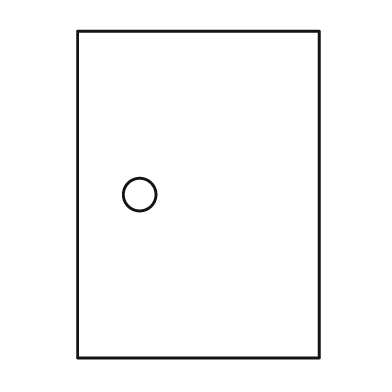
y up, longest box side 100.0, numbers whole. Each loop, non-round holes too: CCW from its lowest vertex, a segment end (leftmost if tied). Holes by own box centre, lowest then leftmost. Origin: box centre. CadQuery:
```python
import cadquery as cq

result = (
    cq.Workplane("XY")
    .moveTo(-37.0, -50.0)
    .lineTo(37.0, -50.0)
    .lineTo(37.0, 50.0)
    .lineTo(-37.0, 50.0)
    .close()
    .moveTo(-18.0, 0.0)
    .circle(5.0)
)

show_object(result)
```